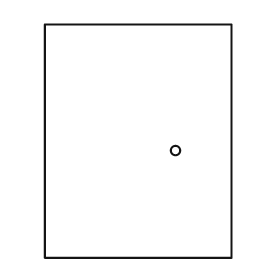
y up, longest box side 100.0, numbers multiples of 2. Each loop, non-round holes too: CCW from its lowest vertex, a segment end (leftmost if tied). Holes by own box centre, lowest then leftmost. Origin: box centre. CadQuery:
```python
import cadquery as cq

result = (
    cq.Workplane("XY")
    .moveTo(-40.0, -50.0)
    .lineTo(40.0, -50.0)
    .lineTo(40.0, 50.0)
    .lineTo(-40.0, 50.0)
    .close()
    .moveTo(16.0, -4.0)
    .circle(2.0)
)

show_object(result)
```